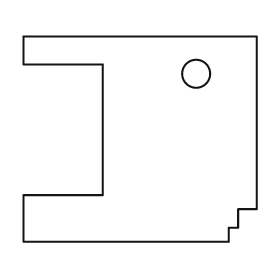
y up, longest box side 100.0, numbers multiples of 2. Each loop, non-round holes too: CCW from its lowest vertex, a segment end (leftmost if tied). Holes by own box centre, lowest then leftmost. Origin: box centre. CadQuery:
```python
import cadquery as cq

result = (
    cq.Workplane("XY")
    .moveTo(-50.0, -44.0)
    .lineTo(38.0, -44.0)
    .lineTo(38.0, -38.0)
    .lineTo(42.0, -38.0)
    .lineTo(42.0, -30.0)
    .lineTo(50.0, -30.0)
    .lineTo(50.0, 44.0)
    .lineTo(-50.0, 44.0)
    .lineTo(-50.0, 32.0)
    .lineTo(-16.0, 32.0)
    .lineTo(-16.0, -24.0)
    .lineTo(-50.0, -24.0)
    .close()
    .moveTo(24.0, 28.0)
    .circle(6.0)
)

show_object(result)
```